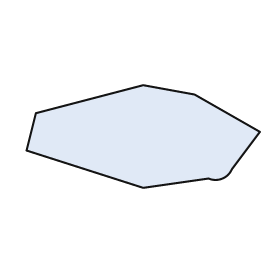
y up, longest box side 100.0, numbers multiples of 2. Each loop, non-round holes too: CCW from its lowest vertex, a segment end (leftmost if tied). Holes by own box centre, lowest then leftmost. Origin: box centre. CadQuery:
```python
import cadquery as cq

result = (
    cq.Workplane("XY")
    .moveTo(0.0, -22.0)
    .lineTo(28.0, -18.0)
    .threePointArc((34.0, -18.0), (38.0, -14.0))
    .lineTo(50.0, 2.0)
    .lineTo(22.0, 18.0)
    .lineTo(0.0, 22.0)
    .lineTo(-46.0, 10.0)
    .lineTo(-50.0, -6.0)
    .close()
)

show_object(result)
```